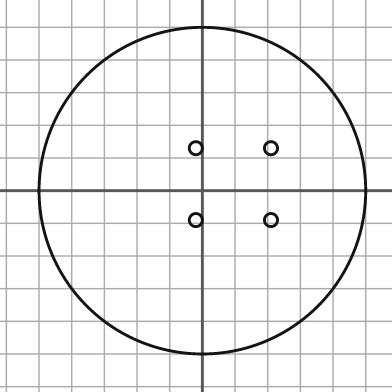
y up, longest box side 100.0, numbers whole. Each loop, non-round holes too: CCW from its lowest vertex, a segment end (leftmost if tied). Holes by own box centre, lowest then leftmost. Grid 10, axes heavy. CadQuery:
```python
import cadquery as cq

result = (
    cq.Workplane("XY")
    .moveTo(0.0, 0.0)
    .circle(50.0)
    .moveTo(-2.0, -9.0)
    .circle(2.0)
    .moveTo(21.0, -9.0)
    .circle(2.0)
    .moveTo(-2.0, 13.0)
    .circle(2.0)
    .moveTo(21.0, 13.0)
    .circle(2.0)
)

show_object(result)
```